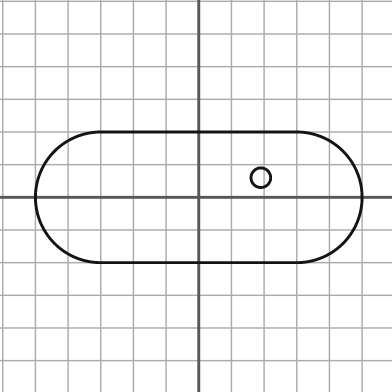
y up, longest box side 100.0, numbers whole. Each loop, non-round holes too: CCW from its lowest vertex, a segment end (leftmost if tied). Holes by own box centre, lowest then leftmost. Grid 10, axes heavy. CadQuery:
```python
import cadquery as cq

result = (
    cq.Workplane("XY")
    .moveTo(-30.0, -20.0)
    .lineTo(30.0, -20.0)
    .threePointArc((50.0, 0.0), (30.0, 20.0))
    .lineTo(-30.0, 20.0)
    .threePointArc((-50.0, 0.0), (-30.0, -20.0))
    .close()
    .moveTo(19.0, 6.0)
    .circle(3.0)
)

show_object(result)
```